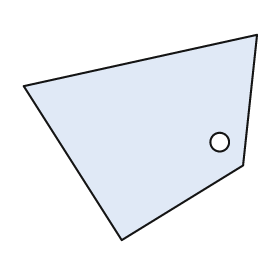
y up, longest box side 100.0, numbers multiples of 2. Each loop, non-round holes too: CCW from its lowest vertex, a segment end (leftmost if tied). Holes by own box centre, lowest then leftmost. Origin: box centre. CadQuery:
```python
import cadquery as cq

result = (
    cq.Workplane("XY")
    .moveTo(-8.0, -44.0)
    .lineTo(44.0, -12.0)
    .lineTo(50.0, 44.0)
    .lineTo(-50.0, 22.0)
    .close()
    .moveTo(34.0, -2.0)
    .circle(4.0)
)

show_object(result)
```